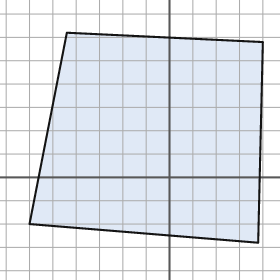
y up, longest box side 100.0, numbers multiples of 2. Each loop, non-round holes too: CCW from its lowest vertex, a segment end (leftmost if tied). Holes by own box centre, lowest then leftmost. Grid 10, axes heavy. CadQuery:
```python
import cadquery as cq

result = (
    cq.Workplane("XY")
    .moveTo(38.0, -28.0)
    .lineTo(40.0, 58.0)
    .lineTo(-44.0, 62.0)
    .lineTo(-60.0, -20.0)
    .close()
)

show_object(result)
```